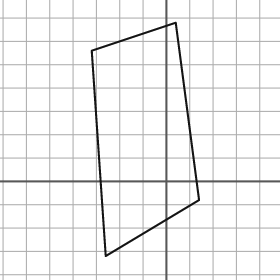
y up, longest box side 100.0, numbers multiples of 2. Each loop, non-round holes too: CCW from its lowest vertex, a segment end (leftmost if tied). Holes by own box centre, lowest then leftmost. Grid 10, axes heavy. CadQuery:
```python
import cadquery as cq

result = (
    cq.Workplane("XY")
    .moveTo(-26.0, -32.0)
    .lineTo(14.0, -8.0)
    .lineTo(4.0, 68.0)
    .lineTo(-32.0, 56.0)
    .close()
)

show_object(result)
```